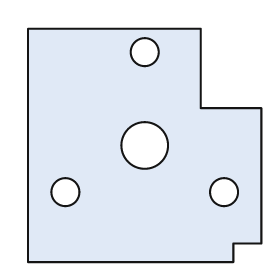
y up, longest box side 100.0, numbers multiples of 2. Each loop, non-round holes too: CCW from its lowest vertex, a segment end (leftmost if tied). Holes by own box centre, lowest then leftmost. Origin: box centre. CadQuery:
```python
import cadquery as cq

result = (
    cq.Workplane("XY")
    .moveTo(-50.0, -50.0)
    .lineTo(38.0, -50.0)
    .lineTo(38.0, -42.0)
    .lineTo(50.0, -42.0)
    .lineTo(50.0, 16.0)
    .lineTo(24.0, 16.0)
    .lineTo(24.0, 50.0)
    .lineTo(-50.0, 50.0)
    .close()
    .moveTo(-34.0, -20.0)
    .circle(6.0)
    .moveTo(34.0, -20.0)
    .circle(6.0)
    .moveTo(0.0, 0.0)
    .circle(10.0)
    .moveTo(0.0, 40.0)
    .circle(6.0)
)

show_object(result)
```